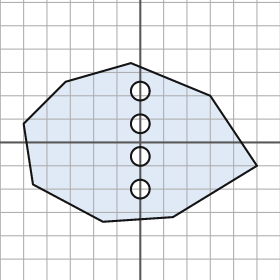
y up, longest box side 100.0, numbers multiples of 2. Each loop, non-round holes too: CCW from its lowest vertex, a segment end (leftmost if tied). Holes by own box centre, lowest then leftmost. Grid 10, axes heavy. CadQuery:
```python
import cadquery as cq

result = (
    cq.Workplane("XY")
    .moveTo(-16.0, -34.0)
    .lineTo(14.0, -32.0)
    .lineTo(50.0, -10.0)
    .lineTo(30.0, 20.0)
    .lineTo(-4.0, 34.0)
    .lineTo(-32.0, 26.0)
    .lineTo(-50.0, 8.0)
    .lineTo(-46.0, -18.0)
    .close()
    .moveTo(0.0, -20.0)
    .circle(4.0)
    .moveTo(0.0, -6.0)
    .circle(4.0)
    .moveTo(0.0, 8.0)
    .circle(4.0)
    .moveTo(0.0, 22.0)
    .circle(4.0)
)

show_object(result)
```